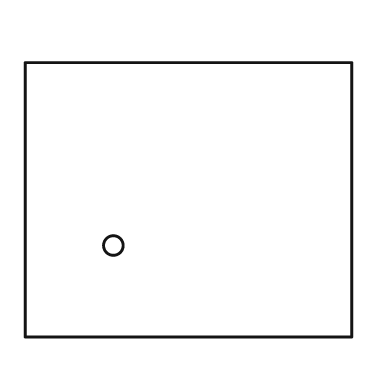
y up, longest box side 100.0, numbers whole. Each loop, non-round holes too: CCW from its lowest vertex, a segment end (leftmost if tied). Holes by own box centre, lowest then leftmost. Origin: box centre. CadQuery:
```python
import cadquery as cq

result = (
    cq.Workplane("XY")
    .moveTo(-50.0, -42.0)
    .lineTo(50.0, -42.0)
    .lineTo(50.0, 42.0)
    .lineTo(-50.0, 42.0)
    .close()
    .moveTo(-23.0, -14.0)
    .circle(3.0)
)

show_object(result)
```